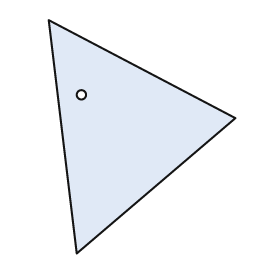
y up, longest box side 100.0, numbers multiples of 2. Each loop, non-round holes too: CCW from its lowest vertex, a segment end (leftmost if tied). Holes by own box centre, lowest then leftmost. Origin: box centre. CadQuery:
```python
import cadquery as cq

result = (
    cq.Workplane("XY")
    .moveTo(-28.0, -50.0)
    .lineTo(40.0, 8.0)
    .lineTo(-40.0, 50.0)
    .close()
    .moveTo(-26.0, 18.0)
    .circle(2.0)
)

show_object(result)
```